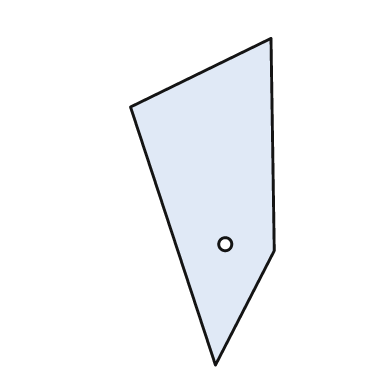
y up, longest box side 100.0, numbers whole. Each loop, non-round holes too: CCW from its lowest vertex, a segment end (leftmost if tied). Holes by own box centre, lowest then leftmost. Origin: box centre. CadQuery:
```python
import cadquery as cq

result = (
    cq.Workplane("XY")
    .moveTo(4.0, -50.0)
    .lineTo(22.0, -15.0)
    .lineTo(21.0, 50.0)
    .lineTo(-22.0, 29.0)
    .close()
    .moveTo(7.0, -13.0)
    .circle(2.0)
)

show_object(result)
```